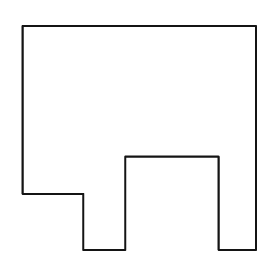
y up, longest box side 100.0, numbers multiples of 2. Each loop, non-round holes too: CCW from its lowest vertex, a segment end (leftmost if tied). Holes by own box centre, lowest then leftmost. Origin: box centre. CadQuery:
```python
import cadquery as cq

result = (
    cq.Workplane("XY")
    .moveTo(-24.0, -48.0)
    .lineTo(-6.0, -48.0)
    .lineTo(-6.0, -8.0)
    .lineTo(34.0, -8.0)
    .lineTo(34.0, -48.0)
    .lineTo(50.0, -48.0)
    .lineTo(50.0, 48.0)
    .lineTo(-50.0, 48.0)
    .lineTo(-50.0, -24.0)
    .lineTo(-24.0, -24.0)
    .close()
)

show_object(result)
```